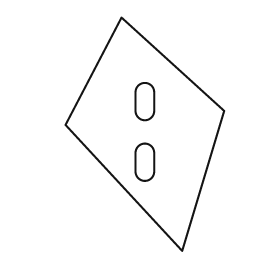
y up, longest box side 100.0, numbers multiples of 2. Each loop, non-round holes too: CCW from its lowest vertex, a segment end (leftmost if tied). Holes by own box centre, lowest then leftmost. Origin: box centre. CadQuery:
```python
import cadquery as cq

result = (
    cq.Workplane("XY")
    .moveTo(16.0, -50.0)
    .lineTo(34.0, 10.0)
    .lineTo(-10.0, 50.0)
    .lineTo(-34.0, 4.0)
    .close()
    .moveTo(-4.0, -16.0)
    .threePointArc((0.0, -20.0), (4.0, -16.0))
    .lineTo(4.0, -8.0)
    .threePointArc((0.0, -4.0), (-4.0, -8.0))
    .close()
    .moveTo(-4.0, 10.0)
    .threePointArc((0.0, 6.0), (4.0, 10.0))
    .lineTo(4.0, 18.0)
    .threePointArc((0.0, 22.0), (-4.0, 18.0))
    .close()
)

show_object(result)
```